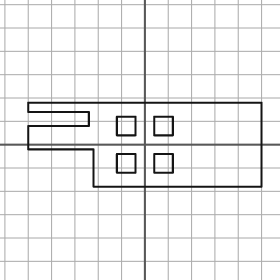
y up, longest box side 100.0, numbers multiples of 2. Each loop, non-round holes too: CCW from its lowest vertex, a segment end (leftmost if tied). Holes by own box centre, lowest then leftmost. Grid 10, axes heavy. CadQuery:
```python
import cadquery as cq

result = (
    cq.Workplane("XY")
    .moveTo(-22.0, -18.0)
    .lineTo(50.0, -18.0)
    .lineTo(50.0, 18.0)
    .lineTo(-50.0, 18.0)
    .lineTo(-50.0, 14.0)
    .lineTo(-24.0, 14.0)
    .lineTo(-24.0, 8.0)
    .lineTo(-50.0, 8.0)
    .lineTo(-50.0, -2.0)
    .lineTo(-22.0, -2.0)
    .close()
    .moveTo(-12.0, -12.0)
    .lineTo(-4.0, -12.0)
    .lineTo(-4.0, -4.0)
    .lineTo(-12.0, -4.0)
    .close()
    .moveTo(4.0, -12.0)
    .lineTo(12.0, -12.0)
    .lineTo(12.0, -4.0)
    .lineTo(4.0, -4.0)
    .close()
    .moveTo(-12.0, 4.0)
    .lineTo(-4.0, 4.0)
    .lineTo(-4.0, 12.0)
    .lineTo(-12.0, 12.0)
    .close()
    .moveTo(4.0, 4.0)
    .lineTo(12.0, 4.0)
    .lineTo(12.0, 12.0)
    .lineTo(4.0, 12.0)
    .close()
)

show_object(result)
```